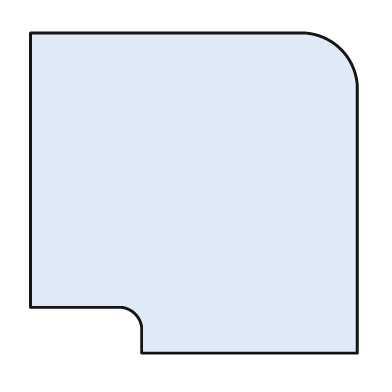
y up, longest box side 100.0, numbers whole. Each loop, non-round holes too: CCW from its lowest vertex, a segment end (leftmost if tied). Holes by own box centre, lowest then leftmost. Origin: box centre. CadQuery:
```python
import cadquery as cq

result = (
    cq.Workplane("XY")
    .moveTo(-16.0, -49.0)
    .lineTo(50.0, -49.0)
    .lineTo(50.0, 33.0)
    .threePointArc((45.0, 44.0), (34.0, 49.0))
    .lineTo(-50.0, 49.0)
    .lineTo(-50.0, -35.0)
    .lineTo(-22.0, -35.0)
    .threePointArc((-18.0, -37.0), (-16.0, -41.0))
    .close()
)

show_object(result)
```